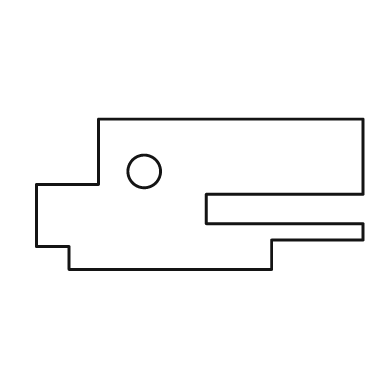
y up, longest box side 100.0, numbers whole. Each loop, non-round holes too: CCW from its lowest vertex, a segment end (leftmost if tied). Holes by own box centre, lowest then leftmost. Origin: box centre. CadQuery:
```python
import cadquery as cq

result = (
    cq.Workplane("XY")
    .moveTo(-40.0, -23.0)
    .lineTo(22.0, -23.0)
    .lineTo(22.0, -14.0)
    .lineTo(50.0, -14.0)
    .lineTo(50.0, -9.0)
    .lineTo(2.0, -9.0)
    .lineTo(2.0, 0.0)
    .lineTo(50.0, 0.0)
    .lineTo(50.0, 23.0)
    .lineTo(-31.0, 23.0)
    .lineTo(-31.0, 3.0)
    .lineTo(-50.0, 3.0)
    .lineTo(-50.0, -16.0)
    .lineTo(-40.0, -16.0)
    .close()
    .moveTo(-17.0, 7.0)
    .circle(5.0)
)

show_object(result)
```